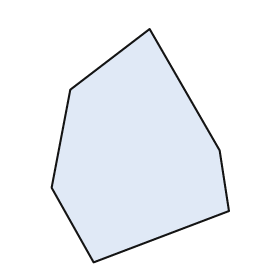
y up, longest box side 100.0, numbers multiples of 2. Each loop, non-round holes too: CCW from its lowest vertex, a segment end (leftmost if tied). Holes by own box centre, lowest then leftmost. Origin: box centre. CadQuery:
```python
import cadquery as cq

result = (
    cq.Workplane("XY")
    .moveTo(-20.0, -50.0)
    .lineTo(38.0, -28.0)
    .lineTo(34.0, -2.0)
    .lineTo(4.0, 50.0)
    .lineTo(-30.0, 24.0)
    .lineTo(-38.0, -18.0)
    .close()
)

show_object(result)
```